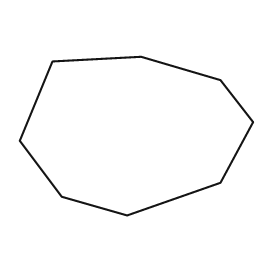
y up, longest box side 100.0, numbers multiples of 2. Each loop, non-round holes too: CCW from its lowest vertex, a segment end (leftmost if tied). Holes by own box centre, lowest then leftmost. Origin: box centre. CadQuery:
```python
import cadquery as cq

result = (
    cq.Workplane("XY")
    .moveTo(-4.0, -34.0)
    .lineTo(36.0, -20.0)
    .lineTo(50.0, 6.0)
    .lineTo(36.0, 24.0)
    .lineTo(2.0, 34.0)
    .lineTo(-36.0, 32.0)
    .lineTo(-50.0, -2.0)
    .lineTo(-32.0, -26.0)
    .close()
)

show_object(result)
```